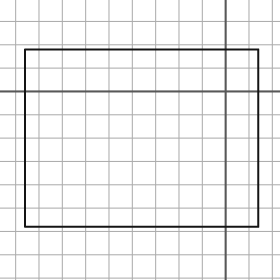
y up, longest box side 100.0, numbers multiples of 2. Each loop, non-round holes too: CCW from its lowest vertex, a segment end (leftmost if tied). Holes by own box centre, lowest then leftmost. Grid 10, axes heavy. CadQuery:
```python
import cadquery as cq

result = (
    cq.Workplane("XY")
    .moveTo(-86.0, -58.0)
    .lineTo(14.0, -58.0)
    .lineTo(14.0, 18.0)
    .lineTo(-86.0, 18.0)
    .close()
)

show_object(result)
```